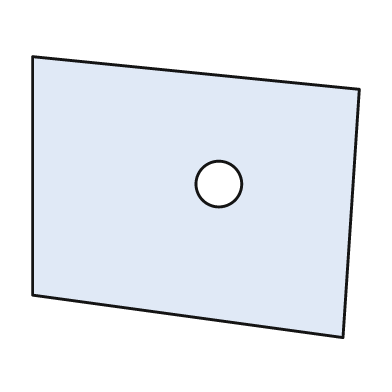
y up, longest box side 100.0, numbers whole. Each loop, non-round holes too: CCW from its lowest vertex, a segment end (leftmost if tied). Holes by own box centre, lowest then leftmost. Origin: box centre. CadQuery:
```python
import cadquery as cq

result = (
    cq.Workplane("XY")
    .moveTo(45.0, -43.0)
    .lineTo(50.0, 33.0)
    .lineTo(-50.0, 43.0)
    .lineTo(-50.0, -30.0)
    .close()
    .moveTo(7.0, 4.0)
    .circle(7.0)
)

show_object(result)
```